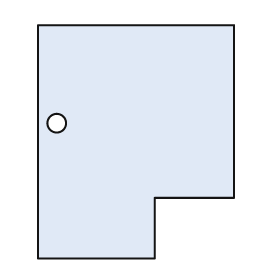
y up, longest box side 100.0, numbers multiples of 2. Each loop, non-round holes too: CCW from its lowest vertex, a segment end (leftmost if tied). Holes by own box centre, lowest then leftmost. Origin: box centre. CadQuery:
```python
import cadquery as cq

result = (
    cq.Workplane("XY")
    .moveTo(-42.0, -50.0)
    .lineTo(8.0, -50.0)
    .lineTo(8.0, -24.0)
    .lineTo(42.0, -24.0)
    .lineTo(42.0, 50.0)
    .lineTo(-42.0, 50.0)
    .close()
    .moveTo(-34.0, 8.0)
    .circle(4.0)
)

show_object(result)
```